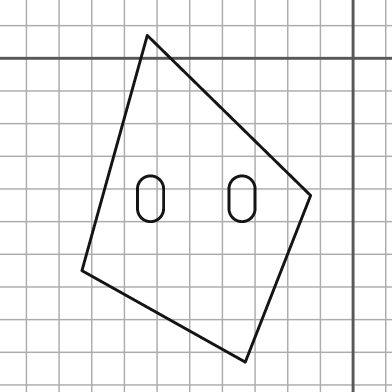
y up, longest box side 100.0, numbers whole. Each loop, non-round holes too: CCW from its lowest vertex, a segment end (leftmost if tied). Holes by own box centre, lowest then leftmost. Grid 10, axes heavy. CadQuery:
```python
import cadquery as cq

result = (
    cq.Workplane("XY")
    .moveTo(-33.0, -93.0)
    .lineTo(-13.0, -42.0)
    .lineTo(-63.0, 7.0)
    .lineTo(-83.0, -65.0)
    .close()
    .moveTo(-66.0, -46.0)
    .threePointArc((-62.0, -50.0), (-58.0, -46.0))
    .lineTo(-58.0, -40.0)
    .threePointArc((-62.0, -36.0), (-66.0, -40.0))
    .close()
    .moveTo(-38.0, -46.0)
    .threePointArc((-34.0, -50.0), (-30.0, -46.0))
    .lineTo(-30.0, -40.0)
    .threePointArc((-34.0, -36.0), (-38.0, -40.0))
    .close()
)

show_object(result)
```